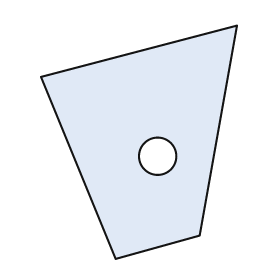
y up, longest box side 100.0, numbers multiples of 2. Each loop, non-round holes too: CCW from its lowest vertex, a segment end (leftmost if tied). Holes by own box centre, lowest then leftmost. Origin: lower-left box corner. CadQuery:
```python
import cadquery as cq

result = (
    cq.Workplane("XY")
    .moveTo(32.0, 0.0)
    .lineTo(68.0, 10.0)
    .lineTo(84.0, 100.0)
    .lineTo(0.0, 78.0)
    .close()
    .moveTo(50.0, 44.0)
    .circle(8.0)
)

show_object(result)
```